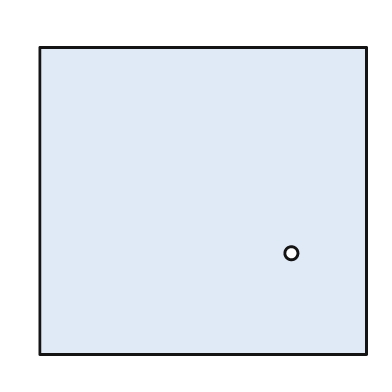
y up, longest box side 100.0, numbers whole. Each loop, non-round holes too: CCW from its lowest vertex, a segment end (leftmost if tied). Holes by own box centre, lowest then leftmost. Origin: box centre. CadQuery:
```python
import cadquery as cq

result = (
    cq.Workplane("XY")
    .moveTo(-50.0, -47.0)
    .lineTo(50.0, -47.0)
    .lineTo(50.0, 47.0)
    .lineTo(-50.0, 47.0)
    .close()
    .moveTo(27.0, -16.0)
    .circle(2.0)
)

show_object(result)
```